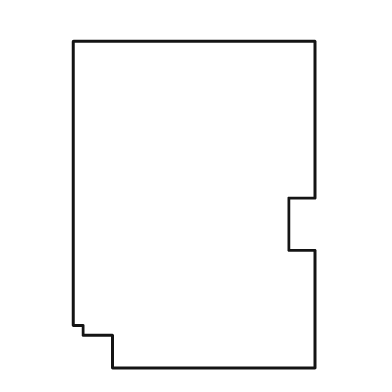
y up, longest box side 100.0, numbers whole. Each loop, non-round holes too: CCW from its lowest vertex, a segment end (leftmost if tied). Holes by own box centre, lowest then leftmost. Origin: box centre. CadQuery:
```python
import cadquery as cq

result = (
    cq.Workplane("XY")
    .moveTo(-25.0, -50.0)
    .lineTo(37.0, -50.0)
    .lineTo(37.0, -14.0)
    .lineTo(29.0, -14.0)
    .lineTo(29.0, 2.0)
    .lineTo(37.0, 2.0)
    .lineTo(37.0, 50.0)
    .lineTo(-37.0, 50.0)
    .lineTo(-37.0, -37.0)
    .lineTo(-34.0, -37.0)
    .lineTo(-34.0, -40.0)
    .lineTo(-25.0, -40.0)
    .close()
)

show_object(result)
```